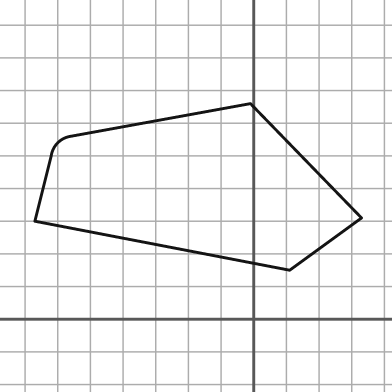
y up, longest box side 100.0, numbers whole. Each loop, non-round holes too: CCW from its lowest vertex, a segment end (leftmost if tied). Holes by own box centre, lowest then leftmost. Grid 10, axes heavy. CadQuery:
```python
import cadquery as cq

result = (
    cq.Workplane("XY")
    .moveTo(11.0, 15.0)
    .lineTo(33.0, 31.0)
    .lineTo(-1.0, 66.0)
    .lineTo(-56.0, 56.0)
    .threePointArc((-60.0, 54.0), (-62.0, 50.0))
    .lineTo(-67.0, 30.0)
    .close()
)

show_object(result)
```